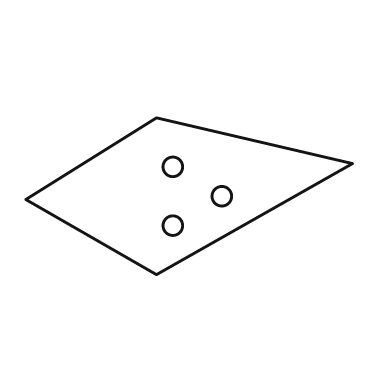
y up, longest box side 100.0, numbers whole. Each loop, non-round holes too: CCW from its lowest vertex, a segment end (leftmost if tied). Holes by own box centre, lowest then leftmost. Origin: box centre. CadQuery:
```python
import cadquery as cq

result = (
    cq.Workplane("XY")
    .moveTo(-10.0, -24.0)
    .lineTo(50.0, 10.0)
    .lineTo(-10.0, 24.0)
    .lineTo(-50.0, -1.0)
    .close()
    .moveTo(-5.0, -9.0)
    .circle(3.0)
    .moveTo(10.0, 0.0)
    .circle(3.0)
    .moveTo(-5.0, 9.0)
    .circle(3.0)
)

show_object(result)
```